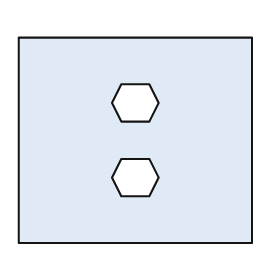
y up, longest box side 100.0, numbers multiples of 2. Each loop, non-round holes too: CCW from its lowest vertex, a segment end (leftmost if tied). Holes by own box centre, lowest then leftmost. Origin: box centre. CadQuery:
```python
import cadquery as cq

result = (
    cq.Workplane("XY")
    .moveTo(-50.0, -44.0)
    .lineTo(50.0, -44.0)
    .lineTo(50.0, 44.0)
    .lineTo(-50.0, 44.0)
    .close()
    .moveTo(-6.0, -24.0)
    .lineTo(6.0, -24.0)
    .lineTo(10.0, -16.0)
    .lineTo(6.0, -8.0)
    .lineTo(-6.0, -8.0)
    .lineTo(-10.0, -16.0)
    .close()
    .moveTo(-6.0, 8.0)
    .lineTo(6.0, 8.0)
    .lineTo(10.0, 16.0)
    .lineTo(6.0, 24.0)
    .lineTo(-6.0, 24.0)
    .lineTo(-10.0, 16.0)
    .close()
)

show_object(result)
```